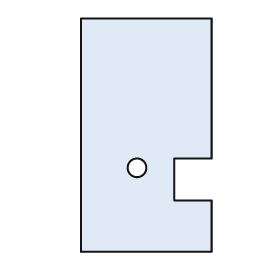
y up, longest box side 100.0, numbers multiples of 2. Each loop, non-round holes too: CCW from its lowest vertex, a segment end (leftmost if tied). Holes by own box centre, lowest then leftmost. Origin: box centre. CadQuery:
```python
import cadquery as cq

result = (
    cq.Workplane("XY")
    .moveTo(-28.0, -50.0)
    .lineTo(28.0, -50.0)
    .lineTo(28.0, -28.0)
    .lineTo(12.0, -28.0)
    .lineTo(12.0, -10.0)
    .lineTo(28.0, -10.0)
    .lineTo(28.0, 50.0)
    .lineTo(-28.0, 50.0)
    .close()
    .moveTo(-4.0, -14.0)
    .circle(4.0)
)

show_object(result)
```